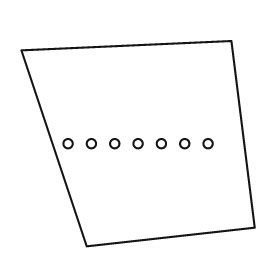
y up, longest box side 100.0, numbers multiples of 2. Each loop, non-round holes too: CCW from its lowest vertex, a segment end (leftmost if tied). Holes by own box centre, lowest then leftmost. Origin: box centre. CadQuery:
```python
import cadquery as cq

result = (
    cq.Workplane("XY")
    .moveTo(-22.0, -44.0)
    .lineTo(50.0, -36.0)
    .lineTo(40.0, 44.0)
    .lineTo(-50.0, 40.0)
    .close()
    .moveTo(-30.0, 0.0)
    .circle(2.0)
    .moveTo(-20.0, 0.0)
    .circle(2.0)
    .moveTo(-10.0, 0.0)
    .circle(2.0)
    .moveTo(0.0, 0.0)
    .circle(2.0)
    .moveTo(10.0, 0.0)
    .circle(2.0)
    .moveTo(20.0, 0.0)
    .circle(2.0)
    .moveTo(30.0, 0.0)
    .circle(2.0)
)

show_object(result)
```